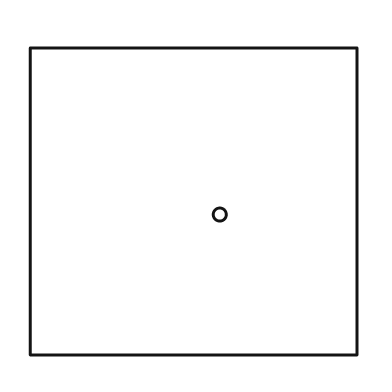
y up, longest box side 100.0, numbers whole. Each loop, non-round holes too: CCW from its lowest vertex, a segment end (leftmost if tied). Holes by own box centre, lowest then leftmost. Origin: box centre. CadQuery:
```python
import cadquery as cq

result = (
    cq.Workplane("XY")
    .moveTo(-50.0, -47.0)
    .lineTo(50.0, -47.0)
    .lineTo(50.0, 47.0)
    .lineTo(-50.0, 47.0)
    .close()
    .moveTo(8.0, -4.0)
    .circle(2.0)
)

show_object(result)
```